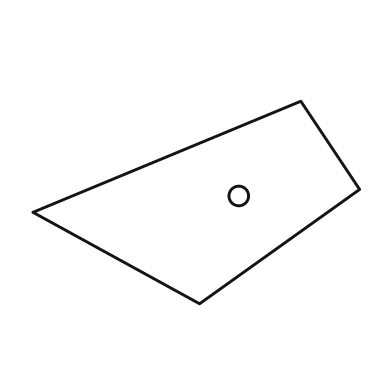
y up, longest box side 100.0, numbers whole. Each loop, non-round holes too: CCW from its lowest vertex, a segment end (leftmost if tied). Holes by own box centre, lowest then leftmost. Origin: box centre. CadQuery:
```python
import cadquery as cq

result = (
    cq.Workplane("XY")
    .moveTo(1.0, -31.0)
    .lineTo(50.0, 4.0)
    .lineTo(32.0, 31.0)
    .lineTo(-50.0, -3.0)
    .close()
    .moveTo(13.0, 2.0)
    .circle(3.0)
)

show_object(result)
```